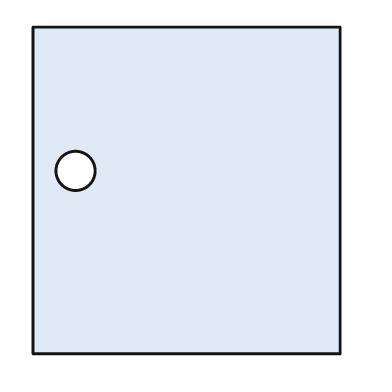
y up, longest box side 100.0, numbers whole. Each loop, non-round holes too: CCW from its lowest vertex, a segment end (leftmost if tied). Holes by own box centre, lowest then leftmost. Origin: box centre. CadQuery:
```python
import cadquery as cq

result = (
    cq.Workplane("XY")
    .moveTo(-47.0, -50.0)
    .lineTo(47.0, -50.0)
    .lineTo(47.0, 50.0)
    .lineTo(-47.0, 50.0)
    .close()
    .moveTo(-34.0, 6.0)
    .circle(6.0)
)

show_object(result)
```